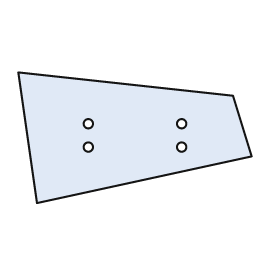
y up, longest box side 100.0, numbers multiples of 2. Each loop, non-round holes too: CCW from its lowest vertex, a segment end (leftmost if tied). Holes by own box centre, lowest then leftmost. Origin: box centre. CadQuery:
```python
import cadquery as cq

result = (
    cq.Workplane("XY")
    .moveTo(-42.0, -28.0)
    .lineTo(50.0, -8.0)
    .lineTo(42.0, 18.0)
    .lineTo(-50.0, 28.0)
    .close()
    .moveTo(-20.0, -4.0)
    .circle(2.0)
    .moveTo(20.0, -4.0)
    .circle(2.0)
    .moveTo(-20.0, 6.0)
    .circle(2.0)
    .moveTo(20.0, 6.0)
    .circle(2.0)
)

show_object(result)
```